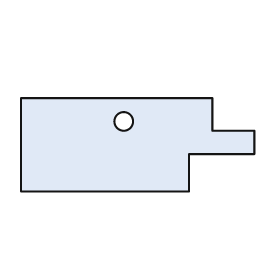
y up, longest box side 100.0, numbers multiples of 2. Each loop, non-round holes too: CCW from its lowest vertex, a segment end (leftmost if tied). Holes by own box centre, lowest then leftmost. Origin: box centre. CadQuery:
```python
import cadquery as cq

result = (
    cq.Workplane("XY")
    .moveTo(-50.0, -20.0)
    .lineTo(22.0, -20.0)
    .lineTo(22.0, -4.0)
    .lineTo(50.0, -4.0)
    .lineTo(50.0, 6.0)
    .lineTo(32.0, 6.0)
    .lineTo(32.0, 20.0)
    .lineTo(-50.0, 20.0)
    .close()
    .moveTo(-6.0, 10.0)
    .circle(4.0)
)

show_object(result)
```